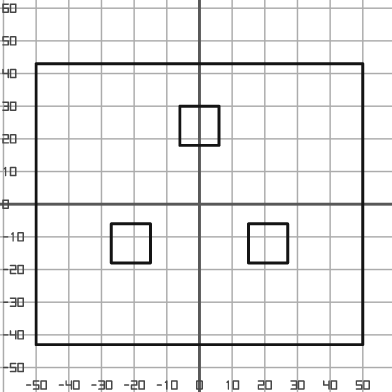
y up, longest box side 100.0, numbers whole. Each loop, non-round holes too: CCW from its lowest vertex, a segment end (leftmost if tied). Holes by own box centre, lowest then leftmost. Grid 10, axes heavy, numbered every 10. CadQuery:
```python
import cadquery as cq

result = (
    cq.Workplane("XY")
    .moveTo(-50.0, -43.0)
    .lineTo(50.0, -43.0)
    .lineTo(50.0, 43.0)
    .lineTo(-50.0, 43.0)
    .close()
    .moveTo(-27.0, -18.0)
    .lineTo(-15.0, -18.0)
    .lineTo(-15.0, -6.0)
    .lineTo(-27.0, -6.0)
    .close()
    .moveTo(15.0, -18.0)
    .lineTo(27.0, -18.0)
    .lineTo(27.0, -6.0)
    .lineTo(15.0, -6.0)
    .close()
    .moveTo(-6.0, 18.0)
    .lineTo(6.0, 18.0)
    .lineTo(6.0, 30.0)
    .lineTo(-6.0, 30.0)
    .close()
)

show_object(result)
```